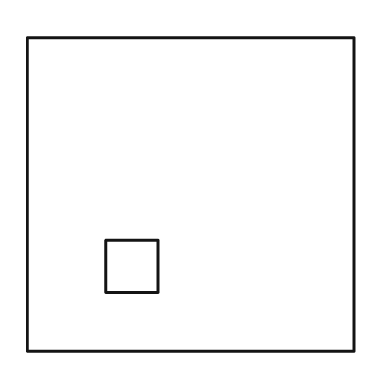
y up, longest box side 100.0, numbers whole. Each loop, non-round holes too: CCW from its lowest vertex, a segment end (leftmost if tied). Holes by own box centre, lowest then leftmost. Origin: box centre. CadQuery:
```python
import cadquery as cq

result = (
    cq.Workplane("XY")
    .moveTo(-50.0, -48.0)
    .lineTo(50.0, -48.0)
    .lineTo(50.0, 48.0)
    .lineTo(-50.0, 48.0)
    .close()
    .moveTo(-26.0, -30.0)
    .lineTo(-10.0, -30.0)
    .lineTo(-10.0, -14.0)
    .lineTo(-26.0, -14.0)
    .close()
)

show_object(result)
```